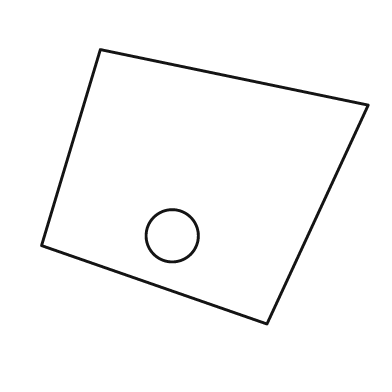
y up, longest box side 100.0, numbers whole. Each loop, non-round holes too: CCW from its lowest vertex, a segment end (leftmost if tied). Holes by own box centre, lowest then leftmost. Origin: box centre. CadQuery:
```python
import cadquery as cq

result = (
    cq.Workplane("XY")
    .moveTo(19.0, -42.0)
    .lineTo(50.0, 25.0)
    .lineTo(-32.0, 42.0)
    .lineTo(-50.0, -18.0)
    .close()
    .moveTo(-10.0, -15.0)
    .circle(8.0)
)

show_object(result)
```